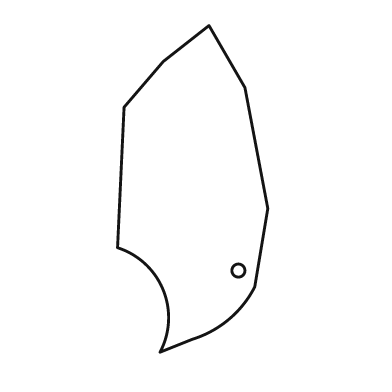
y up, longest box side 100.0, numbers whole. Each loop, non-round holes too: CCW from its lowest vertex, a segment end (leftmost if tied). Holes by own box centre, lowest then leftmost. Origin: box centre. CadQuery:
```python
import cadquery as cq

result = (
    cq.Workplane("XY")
    .moveTo(-10.0, -50.0)
    .lineTo(0.0, -46.0)
    .threePointArc((11.0, -40.0), (19.0, -30.0))
    .lineTo(23.0, -6.0)
    .lineTo(16.0, 31.0)
    .lineTo(5.0, 50.0)
    .lineTo(-9.0, 39.0)
    .lineTo(-21.0, 25.0)
    .lineTo(-23.0, -18.0)
    .threePointArc((-9.0, -31.0), (-10.0, -50.0))
    .close()
    .moveTo(14.0, -25.0)
    .circle(2.0)
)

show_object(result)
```